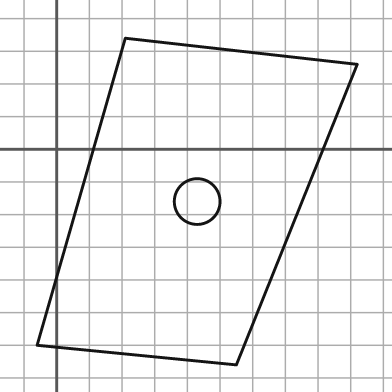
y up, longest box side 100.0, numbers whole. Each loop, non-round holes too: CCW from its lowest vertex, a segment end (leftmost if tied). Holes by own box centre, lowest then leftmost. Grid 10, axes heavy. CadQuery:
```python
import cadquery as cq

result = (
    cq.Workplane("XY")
    .moveTo(55.0, -66.0)
    .lineTo(92.0, 26.0)
    .lineTo(21.0, 34.0)
    .lineTo(-6.0, -60.0)
    .close()
    .moveTo(43.0, -16.0)
    .circle(7.0)
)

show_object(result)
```